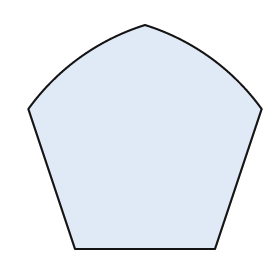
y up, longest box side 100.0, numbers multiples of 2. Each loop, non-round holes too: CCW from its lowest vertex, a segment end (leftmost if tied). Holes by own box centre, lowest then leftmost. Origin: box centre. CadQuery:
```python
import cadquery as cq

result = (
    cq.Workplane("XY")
    .moveTo(-30.0, -48.0)
    .lineTo(30.0, -48.0)
    .lineTo(50.0, 12.0)
    .threePointArc((28.0, 34.0), (0.0, 48.0))
    .threePointArc((-28.0, 34.0), (-50.0, 12.0))
    .close()
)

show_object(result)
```